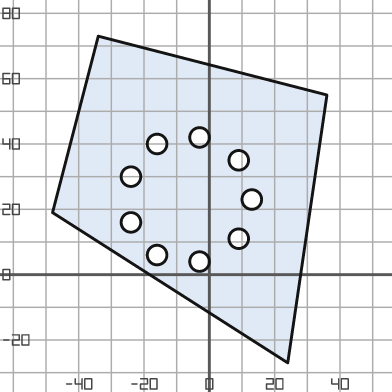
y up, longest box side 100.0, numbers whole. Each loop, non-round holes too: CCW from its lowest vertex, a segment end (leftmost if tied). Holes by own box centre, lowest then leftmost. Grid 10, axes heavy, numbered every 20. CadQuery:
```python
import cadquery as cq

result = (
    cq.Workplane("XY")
    .moveTo(24.0, -27.0)
    .lineTo(36.0, 55.0)
    .lineTo(-34.0, 73.0)
    .lineTo(-48.0, 19.0)
    .close()
    .moveTo(-3.0, 4.0)
    .circle(3.0)
    .moveTo(-16.0, 6.0)
    .circle(3.0)
    .moveTo(9.0, 11.0)
    .circle(3.0)
    .moveTo(-24.0, 16.0)
    .circle(3.0)
    .moveTo(13.0, 23.0)
    .circle(3.0)
    .moveTo(-24.0, 30.0)
    .circle(3.0)
    .moveTo(9.0, 35.0)
    .circle(3.0)
    .moveTo(-16.0, 40.0)
    .circle(3.0)
    .moveTo(-3.0, 42.0)
    .circle(3.0)
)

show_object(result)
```